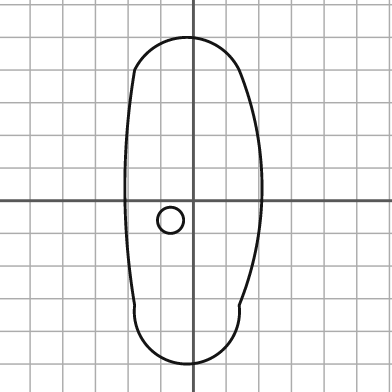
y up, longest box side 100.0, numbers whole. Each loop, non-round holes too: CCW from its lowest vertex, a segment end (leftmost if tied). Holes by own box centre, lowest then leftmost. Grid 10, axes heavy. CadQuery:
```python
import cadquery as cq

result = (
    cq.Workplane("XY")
    .moveTo(-18.0, -32.0)
    .threePointArc((-2.0, -50.0), (14.0, -32.0))
    .threePointArc((21.0, 4.0), (14.0, 40.0))
    .threePointArc((-2.0, 50.0), (-18.0, 40.0))
    .threePointArc((-21.0, 4.0), (-18.0, -32.0))
    .close()
    .moveTo(-7.0, -6.0)
    .circle(4.0)
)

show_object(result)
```